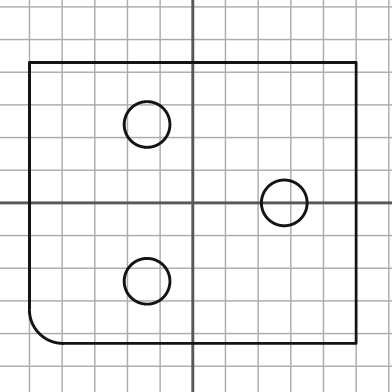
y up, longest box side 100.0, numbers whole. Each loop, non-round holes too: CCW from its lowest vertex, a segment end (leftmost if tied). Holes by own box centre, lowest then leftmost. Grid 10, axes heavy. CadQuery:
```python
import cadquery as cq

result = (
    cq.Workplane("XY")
    .moveTo(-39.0, -43.0)
    .lineTo(50.0, -43.0)
    .lineTo(50.0, 43.0)
    .lineTo(-50.0, 43.0)
    .lineTo(-50.0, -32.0)
    .threePointArc((-47.0, -40.0), (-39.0, -43.0))
    .close()
    .moveTo(-14.0, -24.0)
    .circle(7.0)
    .moveTo(28.0, 0.0)
    .circle(7.0)
    .moveTo(-14.0, 24.0)
    .circle(7.0)
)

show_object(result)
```